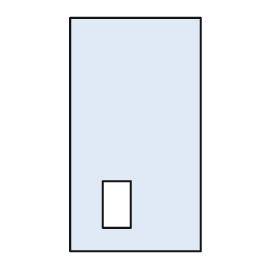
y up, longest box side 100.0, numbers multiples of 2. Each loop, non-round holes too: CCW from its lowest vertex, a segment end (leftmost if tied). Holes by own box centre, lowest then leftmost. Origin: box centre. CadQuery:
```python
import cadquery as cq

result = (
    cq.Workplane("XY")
    .moveTo(-28.0, -50.0)
    .lineTo(28.0, -50.0)
    .lineTo(28.0, 50.0)
    .lineTo(-28.0, 50.0)
    .close()
    .moveTo(-14.0, -40.0)
    .lineTo(-2.0, -40.0)
    .lineTo(-2.0, -20.0)
    .lineTo(-14.0, -20.0)
    .close()
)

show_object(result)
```